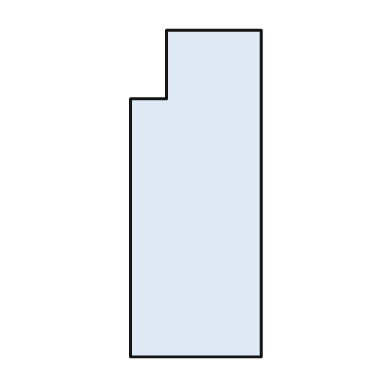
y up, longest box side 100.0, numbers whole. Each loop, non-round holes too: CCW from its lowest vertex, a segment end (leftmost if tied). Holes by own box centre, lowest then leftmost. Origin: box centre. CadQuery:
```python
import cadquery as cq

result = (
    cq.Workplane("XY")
    .moveTo(-20.0, -50.0)
    .lineTo(20.0, -50.0)
    .lineTo(20.0, 50.0)
    .lineTo(-9.0, 50.0)
    .lineTo(-9.0, 29.0)
    .lineTo(-20.0, 29.0)
    .close()
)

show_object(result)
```